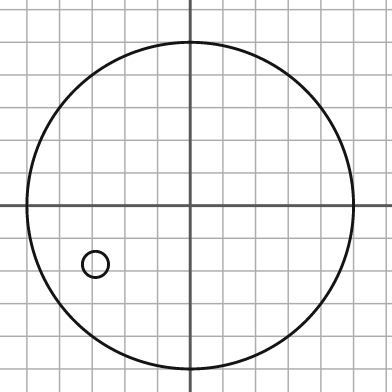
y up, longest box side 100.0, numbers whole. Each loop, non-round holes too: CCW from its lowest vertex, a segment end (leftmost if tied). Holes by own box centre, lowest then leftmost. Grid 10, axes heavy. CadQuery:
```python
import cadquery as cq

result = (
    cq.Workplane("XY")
    .moveTo(0.0, 0.0)
    .circle(50.0)
    .moveTo(-29.0, -18.0)
    .circle(4.0)
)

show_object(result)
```